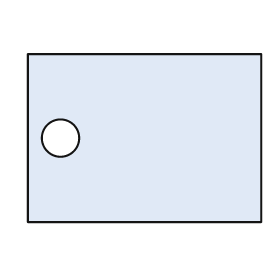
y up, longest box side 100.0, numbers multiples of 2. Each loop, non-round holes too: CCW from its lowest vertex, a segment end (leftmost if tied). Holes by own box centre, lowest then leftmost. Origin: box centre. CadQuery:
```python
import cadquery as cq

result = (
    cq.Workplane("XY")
    .moveTo(-50.0, -36.0)
    .lineTo(50.0, -36.0)
    .lineTo(50.0, 36.0)
    .lineTo(-50.0, 36.0)
    .close()
    .moveTo(-36.0, 0.0)
    .circle(8.0)
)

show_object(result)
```